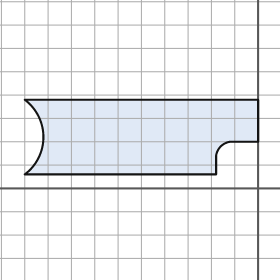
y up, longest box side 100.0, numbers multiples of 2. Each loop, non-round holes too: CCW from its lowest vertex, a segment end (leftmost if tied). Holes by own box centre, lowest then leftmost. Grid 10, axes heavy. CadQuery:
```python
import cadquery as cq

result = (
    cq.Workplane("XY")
    .moveTo(-100.0, 6.0)
    .lineTo(-18.0, 6.0)
    .lineTo(-18.0, 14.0)
    .threePointArc((-16.0, 18.0), (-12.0, 20.0))
    .lineTo(0.0, 20.0)
    .lineTo(0.0, 38.0)
    .lineTo(-100.0, 38.0)
    .threePointArc((-92.0, 22.0), (-100.0, 6.0))
    .close()
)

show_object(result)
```